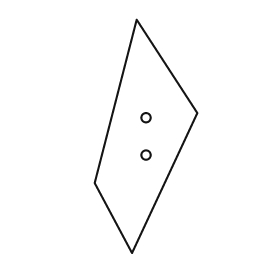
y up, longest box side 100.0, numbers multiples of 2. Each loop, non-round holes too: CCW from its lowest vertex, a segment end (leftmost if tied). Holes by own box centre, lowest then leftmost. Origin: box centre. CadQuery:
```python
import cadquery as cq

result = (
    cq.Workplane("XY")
    .moveTo(-6.0, -50.0)
    .lineTo(22.0, 10.0)
    .lineTo(-4.0, 50.0)
    .lineTo(-22.0, -20.0)
    .close()
    .moveTo(0.0, -8.0)
    .circle(2.0)
    .moveTo(0.0, 8.0)
    .circle(2.0)
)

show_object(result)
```